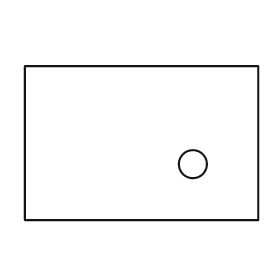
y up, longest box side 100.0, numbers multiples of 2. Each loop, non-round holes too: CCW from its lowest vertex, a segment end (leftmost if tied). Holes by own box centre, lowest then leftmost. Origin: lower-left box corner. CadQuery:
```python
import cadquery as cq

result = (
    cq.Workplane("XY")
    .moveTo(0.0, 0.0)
    .lineTo(100.0, 0.0)
    .lineTo(100.0, 66.0)
    .lineTo(0.0, 66.0)
    .close()
    .moveTo(72.0, 24.0)
    .circle(6.0)
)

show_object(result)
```